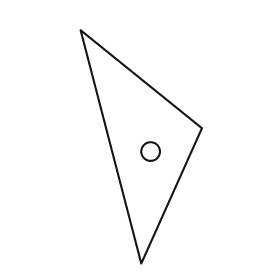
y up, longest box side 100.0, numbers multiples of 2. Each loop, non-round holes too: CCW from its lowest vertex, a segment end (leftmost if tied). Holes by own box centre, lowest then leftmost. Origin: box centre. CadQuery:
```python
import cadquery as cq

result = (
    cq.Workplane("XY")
    .moveTo(0.0, -50.0)
    .lineTo(26.0, 8.0)
    .lineTo(-26.0, 50.0)
    .close()
    .moveTo(4.0, -2.0)
    .circle(4.0)
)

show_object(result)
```